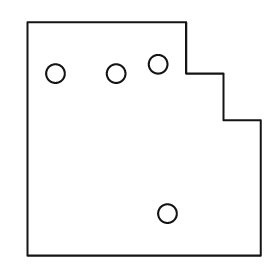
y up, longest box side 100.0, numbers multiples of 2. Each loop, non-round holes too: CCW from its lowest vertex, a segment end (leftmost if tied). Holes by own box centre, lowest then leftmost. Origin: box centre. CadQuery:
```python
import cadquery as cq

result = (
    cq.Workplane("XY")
    .moveTo(-50.0, -50.0)
    .lineTo(50.0, -50.0)
    .lineTo(50.0, 8.0)
    .lineTo(34.0, 8.0)
    .lineTo(34.0, 28.0)
    .lineTo(18.0, 28.0)
    .lineTo(18.0, 50.0)
    .lineTo(-50.0, 50.0)
    .close()
    .moveTo(10.0, -32.0)
    .circle(4.0)
    .moveTo(-38.0, 28.0)
    .circle(4.0)
    .moveTo(-12.0, 28.0)
    .circle(4.0)
    .moveTo(6.0, 32.0)
    .circle(4.0)
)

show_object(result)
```